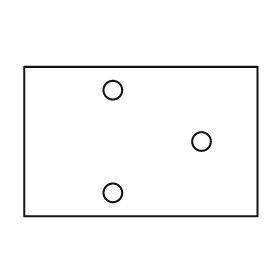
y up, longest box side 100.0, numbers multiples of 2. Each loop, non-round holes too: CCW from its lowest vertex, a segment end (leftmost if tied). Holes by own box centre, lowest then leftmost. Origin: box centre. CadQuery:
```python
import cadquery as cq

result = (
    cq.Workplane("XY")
    .moveTo(-50.0, -32.0)
    .lineTo(50.0, -32.0)
    .lineTo(50.0, 32.0)
    .lineTo(-50.0, 32.0)
    .close()
    .moveTo(-12.0, -22.0)
    .circle(4.0)
    .moveTo(26.0, 0.0)
    .circle(4.0)
    .moveTo(-12.0, 22.0)
    .circle(4.0)
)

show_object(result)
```